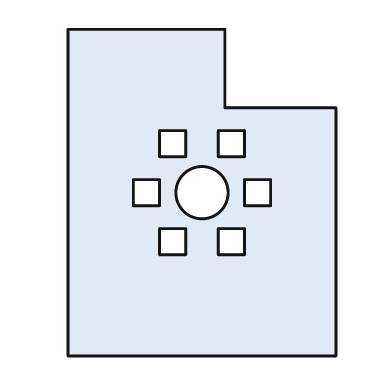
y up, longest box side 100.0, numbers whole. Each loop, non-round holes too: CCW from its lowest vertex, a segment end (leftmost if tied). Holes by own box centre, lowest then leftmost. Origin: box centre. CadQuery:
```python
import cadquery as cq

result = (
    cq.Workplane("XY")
    .moveTo(-41.0, -50.0)
    .lineTo(41.0, -50.0)
    .lineTo(41.0, 26.0)
    .lineTo(7.0, 26.0)
    .lineTo(7.0, 50.0)
    .lineTo(-41.0, 50.0)
    .close()
    .moveTo(-13.0, -19.0)
    .lineTo(-5.0, -19.0)
    .lineTo(-5.0, -11.0)
    .lineTo(-13.0, -11.0)
    .close()
    .moveTo(5.0, -19.0)
    .lineTo(13.0, -19.0)
    .lineTo(13.0, -11.0)
    .lineTo(5.0, -11.0)
    .close()
    .moveTo(-21.0, -4.0)
    .lineTo(-13.0, -4.0)
    .lineTo(-13.0, 4.0)
    .lineTo(-21.0, 4.0)
    .close()
    .moveTo(0.0, 0.0)
    .circle(8.0)
    .moveTo(13.0, -4.0)
    .lineTo(21.0, -4.0)
    .lineTo(21.0, 4.0)
    .lineTo(13.0, 4.0)
    .close()
    .moveTo(-13.0, 11.0)
    .lineTo(-5.0, 11.0)
    .lineTo(-5.0, 19.0)
    .lineTo(-13.0, 19.0)
    .close()
    .moveTo(5.0, 11.0)
    .lineTo(13.0, 11.0)
    .lineTo(13.0, 19.0)
    .lineTo(5.0, 19.0)
    .close()
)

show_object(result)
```